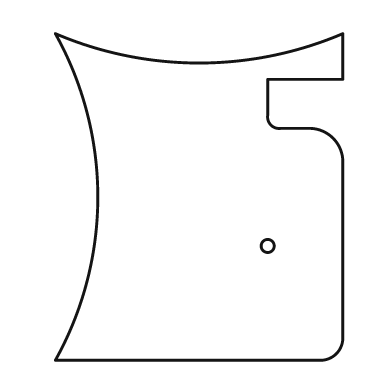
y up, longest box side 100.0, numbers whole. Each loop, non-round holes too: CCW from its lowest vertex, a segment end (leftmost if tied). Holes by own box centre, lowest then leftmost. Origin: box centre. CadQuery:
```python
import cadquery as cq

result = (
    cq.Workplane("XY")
    .moveTo(-44.0, -50.0)
    .lineTo(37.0, -50.0)
    .threePointArc((42.0, -48.0), (44.0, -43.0))
    .lineTo(44.0, 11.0)
    .threePointArc((41.0, 18.0), (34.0, 21.0))
    .lineTo(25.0, 21.0)
    .threePointArc((22.0, 22.0), (21.0, 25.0))
    .lineTo(21.0, 36.0)
    .lineTo(44.0, 36.0)
    .lineTo(44.0, 50.0)
    .threePointArc((0.0, 41.0), (-44.0, 50.0))
    .threePointArc((-31.0, 0.0), (-44.0, -50.0))
    .close()
    .moveTo(21.0, -15.0)
    .circle(2.0)
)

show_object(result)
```